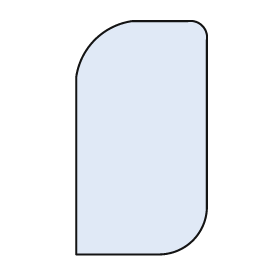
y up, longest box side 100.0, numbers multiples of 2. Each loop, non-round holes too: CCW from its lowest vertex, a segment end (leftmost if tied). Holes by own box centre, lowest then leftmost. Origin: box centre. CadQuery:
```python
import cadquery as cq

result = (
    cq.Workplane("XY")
    .moveTo(-28.0, -50.0)
    .lineTo(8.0, -50.0)
    .threePointArc((22.0, -44.0), (28.0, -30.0))
    .lineTo(28.0, 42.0)
    .threePointArc((26.0, 48.0), (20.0, 50.0))
    .lineTo(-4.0, 50.0)
    .threePointArc((-20.0, 42.0), (-28.0, 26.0))
    .close()
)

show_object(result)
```